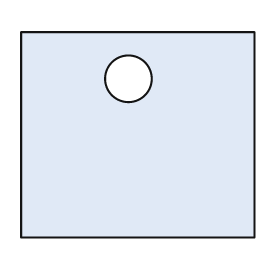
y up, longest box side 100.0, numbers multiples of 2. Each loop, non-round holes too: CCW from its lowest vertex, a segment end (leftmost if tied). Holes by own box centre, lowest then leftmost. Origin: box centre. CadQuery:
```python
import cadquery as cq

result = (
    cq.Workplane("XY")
    .moveTo(-50.0, -44.0)
    .lineTo(50.0, -44.0)
    .lineTo(50.0, 44.0)
    .lineTo(-50.0, 44.0)
    .close()
    .moveTo(-4.0, 24.0)
    .circle(10.0)
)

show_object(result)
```